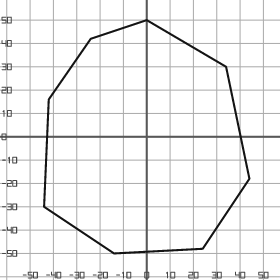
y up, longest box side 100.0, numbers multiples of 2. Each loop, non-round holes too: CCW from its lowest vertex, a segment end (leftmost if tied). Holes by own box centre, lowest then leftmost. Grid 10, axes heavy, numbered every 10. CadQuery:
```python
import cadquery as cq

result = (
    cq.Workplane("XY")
    .moveTo(-14.0, -50.0)
    .lineTo(24.0, -48.0)
    .lineTo(44.0, -18.0)
    .lineTo(34.0, 30.0)
    .lineTo(0.0, 50.0)
    .lineTo(-24.0, 42.0)
    .lineTo(-42.0, 16.0)
    .lineTo(-44.0, -30.0)
    .close()
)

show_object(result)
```